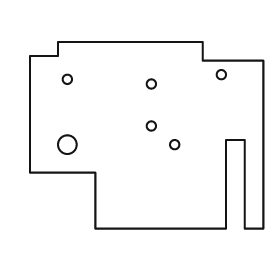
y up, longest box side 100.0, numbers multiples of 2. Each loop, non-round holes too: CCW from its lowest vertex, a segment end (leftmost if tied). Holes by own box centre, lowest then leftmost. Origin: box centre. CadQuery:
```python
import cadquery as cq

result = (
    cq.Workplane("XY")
    .moveTo(-22.0, -40.0)
    .lineTo(34.0, -40.0)
    .lineTo(34.0, -2.0)
    .lineTo(42.0, -2.0)
    .lineTo(42.0, -40.0)
    .lineTo(50.0, -40.0)
    .lineTo(50.0, 32.0)
    .lineTo(24.0, 32.0)
    .lineTo(24.0, 40.0)
    .lineTo(-38.0, 40.0)
    .lineTo(-38.0, 34.0)
    .lineTo(-50.0, 34.0)
    .lineTo(-50.0, -16.0)
    .lineTo(-22.0, -16.0)
    .close()
    .moveTo(-34.0, -4.0)
    .circle(4.0)
    .moveTo(12.0, -4.0)
    .circle(2.0)
    .moveTo(2.0, 4.0)
    .circle(2.0)
    .moveTo(2.0, 22.0)
    .circle(2.0)
    .moveTo(-34.0, 24.0)
    .circle(2.0)
    .moveTo(32.0, 26.0)
    .circle(2.0)
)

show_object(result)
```